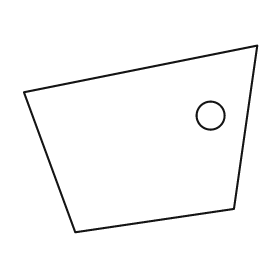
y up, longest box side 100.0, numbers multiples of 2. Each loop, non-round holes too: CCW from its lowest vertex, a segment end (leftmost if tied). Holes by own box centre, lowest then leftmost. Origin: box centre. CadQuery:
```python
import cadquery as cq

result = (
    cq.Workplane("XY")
    .moveTo(-28.0, -40.0)
    .lineTo(40.0, -30.0)
    .lineTo(50.0, 40.0)
    .lineTo(-50.0, 20.0)
    .close()
    .moveTo(30.0, 10.0)
    .circle(6.0)
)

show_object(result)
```